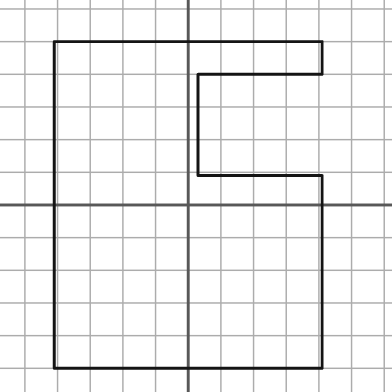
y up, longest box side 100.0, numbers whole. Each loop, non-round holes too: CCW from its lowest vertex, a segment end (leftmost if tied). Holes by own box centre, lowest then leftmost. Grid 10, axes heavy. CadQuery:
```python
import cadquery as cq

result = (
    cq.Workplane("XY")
    .moveTo(-41.0, -50.0)
    .lineTo(41.0, -50.0)
    .lineTo(41.0, 9.0)
    .lineTo(3.0, 9.0)
    .lineTo(3.0, 40.0)
    .lineTo(41.0, 40.0)
    .lineTo(41.0, 50.0)
    .lineTo(-41.0, 50.0)
    .close()
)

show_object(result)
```